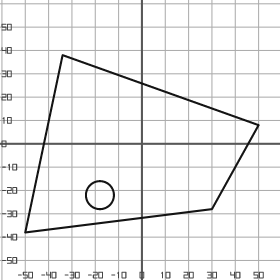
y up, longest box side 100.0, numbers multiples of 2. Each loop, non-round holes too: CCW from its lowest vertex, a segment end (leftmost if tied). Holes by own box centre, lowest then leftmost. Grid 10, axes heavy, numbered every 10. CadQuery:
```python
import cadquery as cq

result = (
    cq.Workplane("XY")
    .moveTo(-50.0, -38.0)
    .lineTo(30.0, -28.0)
    .lineTo(50.0, 8.0)
    .lineTo(-34.0, 38.0)
    .close()
    .moveTo(-18.0, -22.0)
    .circle(6.0)
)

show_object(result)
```